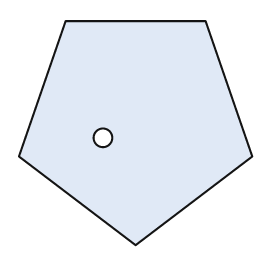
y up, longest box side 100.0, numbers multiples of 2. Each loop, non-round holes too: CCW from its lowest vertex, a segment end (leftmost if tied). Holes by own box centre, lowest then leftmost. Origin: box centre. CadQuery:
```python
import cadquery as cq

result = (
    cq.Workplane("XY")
    .moveTo(0.0, -48.0)
    .lineTo(50.0, -10.0)
    .lineTo(30.0, 48.0)
    .lineTo(-30.0, 48.0)
    .lineTo(-50.0, -10.0)
    .close()
    .moveTo(-14.0, -2.0)
    .circle(4.0)
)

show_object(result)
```